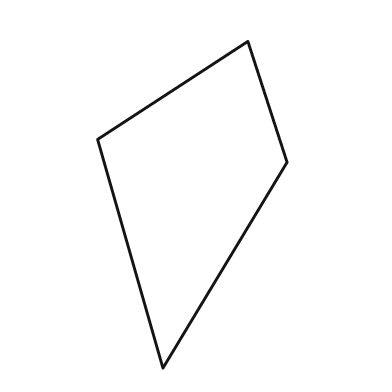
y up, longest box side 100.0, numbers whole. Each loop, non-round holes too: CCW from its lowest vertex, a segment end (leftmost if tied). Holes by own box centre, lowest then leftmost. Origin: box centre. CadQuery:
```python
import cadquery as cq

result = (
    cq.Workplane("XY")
    .moveTo(-9.0, -50.0)
    .lineTo(29.0, 13.0)
    .lineTo(17.0, 50.0)
    .lineTo(-29.0, 20.0)
    .close()
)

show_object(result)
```